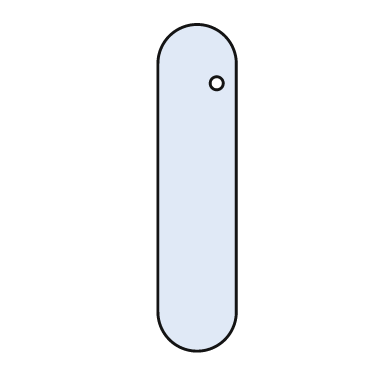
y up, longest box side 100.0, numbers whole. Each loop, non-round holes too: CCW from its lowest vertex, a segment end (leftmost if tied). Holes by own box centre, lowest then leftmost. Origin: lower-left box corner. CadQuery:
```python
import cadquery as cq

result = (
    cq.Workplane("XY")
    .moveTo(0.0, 12.0)
    .threePointArc((12.0, 0.0), (24.0, 12.0))
    .lineTo(24.0, 88.0)
    .threePointArc((12.0, 100.0), (0.0, 88.0))
    .close()
    .moveTo(18.0, 82.0)
    .circle(2.0)
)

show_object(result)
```